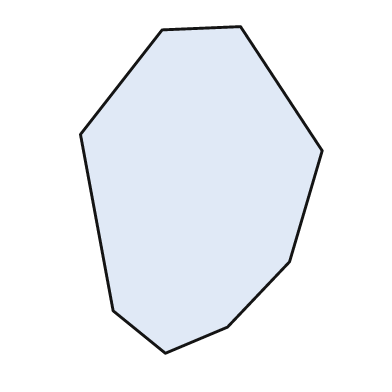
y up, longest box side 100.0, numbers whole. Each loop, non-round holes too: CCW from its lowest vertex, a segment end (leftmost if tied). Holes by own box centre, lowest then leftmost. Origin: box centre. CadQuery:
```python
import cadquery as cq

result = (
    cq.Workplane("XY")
    .moveTo(-11.0, -50.0)
    .lineTo(8.0, -42.0)
    .lineTo(27.0, -22.0)
    .lineTo(37.0, 12.0)
    .lineTo(12.0, 50.0)
    .lineTo(-12.0, 49.0)
    .lineTo(-37.0, 17.0)
    .lineTo(-27.0, -37.0)
    .close()
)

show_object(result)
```